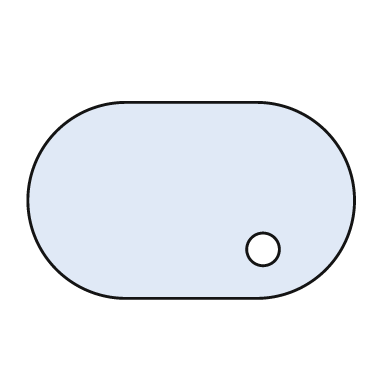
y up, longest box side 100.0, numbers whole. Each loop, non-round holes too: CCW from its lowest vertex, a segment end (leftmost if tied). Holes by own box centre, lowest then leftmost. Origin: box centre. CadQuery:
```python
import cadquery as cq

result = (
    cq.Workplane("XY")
    .moveTo(-20.0, -30.0)
    .lineTo(20.0, -30.0)
    .threePointArc((50.0, 0.0), (20.0, 30.0))
    .lineTo(-20.0, 30.0)
    .threePointArc((-50.0, 0.0), (-20.0, -30.0))
    .close()
    .moveTo(22.0, -15.0)
    .circle(5.0)
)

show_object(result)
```